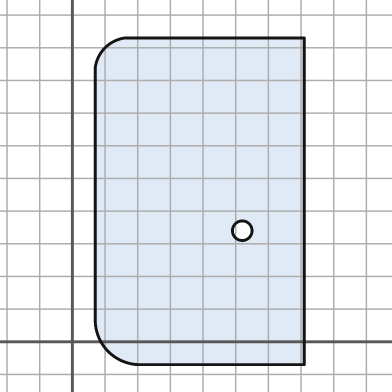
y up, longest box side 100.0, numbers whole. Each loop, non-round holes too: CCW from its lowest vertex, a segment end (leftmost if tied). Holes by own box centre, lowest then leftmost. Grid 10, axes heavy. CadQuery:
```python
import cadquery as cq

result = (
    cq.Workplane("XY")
    .moveTo(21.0, -7.0)
    .lineTo(71.0, -7.0)
    .lineTo(71.0, 93.0)
    .lineTo(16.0, 93.0)
    .threePointArc((10.0, 90.0), (7.0, 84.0))
    .lineTo(7.0, 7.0)
    .threePointArc((11.0, -3.0), (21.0, -7.0))
    .close()
    .moveTo(52.0, 34.0)
    .circle(3.0)
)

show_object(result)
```